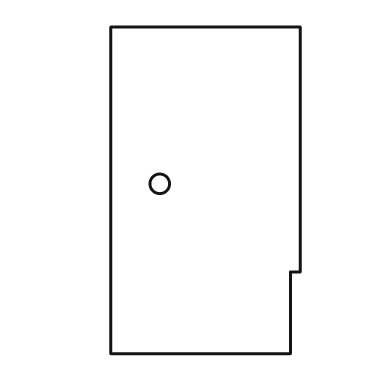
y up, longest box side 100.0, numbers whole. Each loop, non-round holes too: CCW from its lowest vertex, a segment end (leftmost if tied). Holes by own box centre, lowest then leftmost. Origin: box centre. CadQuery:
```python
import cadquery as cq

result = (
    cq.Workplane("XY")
    .moveTo(-29.0, -50.0)
    .lineTo(26.0, -50.0)
    .lineTo(26.0, -25.0)
    .lineTo(29.0, -25.0)
    .lineTo(29.0, 50.0)
    .lineTo(-29.0, 50.0)
    .close()
    .moveTo(-14.0, 2.0)
    .circle(3.0)
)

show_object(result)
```